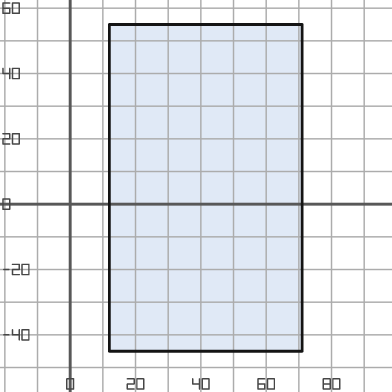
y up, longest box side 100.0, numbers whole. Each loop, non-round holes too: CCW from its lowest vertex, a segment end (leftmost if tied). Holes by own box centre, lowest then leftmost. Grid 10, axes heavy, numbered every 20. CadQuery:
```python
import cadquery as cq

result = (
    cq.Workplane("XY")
    .moveTo(12.0, -45.0)
    .lineTo(71.0, -45.0)
    .lineTo(71.0, 55.0)
    .lineTo(12.0, 55.0)
    .close()
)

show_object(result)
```